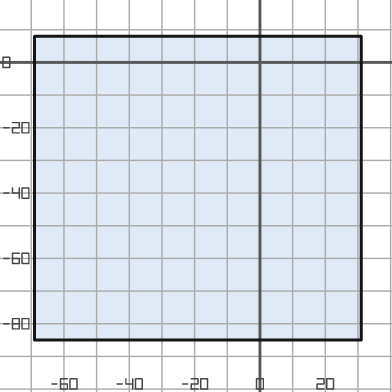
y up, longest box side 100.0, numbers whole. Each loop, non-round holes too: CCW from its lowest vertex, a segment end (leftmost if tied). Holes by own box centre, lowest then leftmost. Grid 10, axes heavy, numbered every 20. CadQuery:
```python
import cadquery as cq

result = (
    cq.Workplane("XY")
    .moveTo(-69.0, -85.0)
    .lineTo(31.0, -85.0)
    .lineTo(31.0, 8.0)
    .lineTo(-69.0, 8.0)
    .close()
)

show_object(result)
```